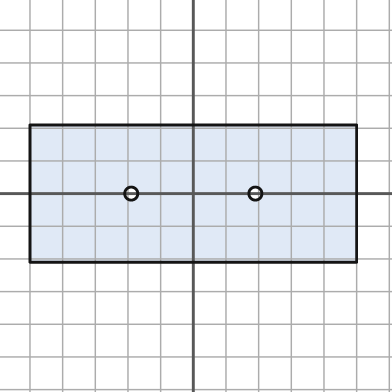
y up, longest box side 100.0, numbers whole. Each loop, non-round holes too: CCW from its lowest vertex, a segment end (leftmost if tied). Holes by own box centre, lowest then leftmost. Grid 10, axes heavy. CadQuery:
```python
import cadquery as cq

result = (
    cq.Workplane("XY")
    .moveTo(-50.0, -21.0)
    .lineTo(50.0, -21.0)
    .lineTo(50.0, 21.0)
    .lineTo(-50.0, 21.0)
    .close()
    .moveTo(-19.0, 0.0)
    .circle(2.0)
    .moveTo(19.0, 0.0)
    .circle(2.0)
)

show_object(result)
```